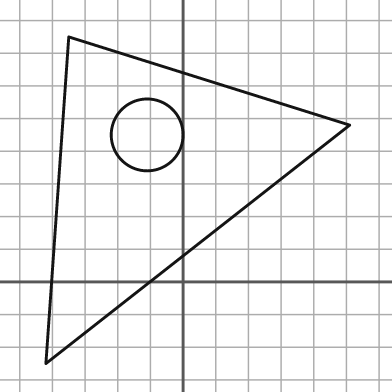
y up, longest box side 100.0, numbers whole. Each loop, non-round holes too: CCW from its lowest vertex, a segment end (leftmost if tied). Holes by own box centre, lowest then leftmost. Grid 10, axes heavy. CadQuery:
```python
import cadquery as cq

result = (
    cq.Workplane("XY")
    .moveTo(-42.0, -25.0)
    .lineTo(51.0, 48.0)
    .lineTo(-35.0, 75.0)
    .close()
    .moveTo(-11.0, 45.0)
    .circle(11.0)
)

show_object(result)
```